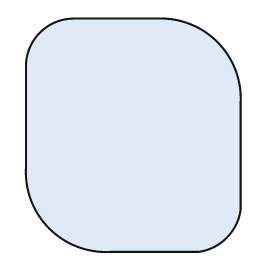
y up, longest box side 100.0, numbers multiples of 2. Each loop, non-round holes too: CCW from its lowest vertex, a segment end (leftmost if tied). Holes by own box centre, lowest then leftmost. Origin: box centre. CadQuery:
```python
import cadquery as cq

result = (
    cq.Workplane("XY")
    .moveTo(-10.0, -50.0)
    .lineTo(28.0, -50.0)
    .threePointArc((40.0, -44.0), (46.0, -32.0))
    .lineTo(46.0, 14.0)
    .threePointArc((36.0, 40.0), (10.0, 50.0))
    .lineTo(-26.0, 50.0)
    .threePointArc((-40.0, 44.0), (-46.0, 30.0))
    .lineTo(-46.0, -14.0)
    .threePointArc((-36.0, -40.0), (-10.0, -50.0))
    .close()
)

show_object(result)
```